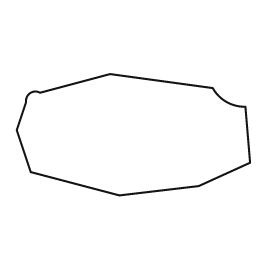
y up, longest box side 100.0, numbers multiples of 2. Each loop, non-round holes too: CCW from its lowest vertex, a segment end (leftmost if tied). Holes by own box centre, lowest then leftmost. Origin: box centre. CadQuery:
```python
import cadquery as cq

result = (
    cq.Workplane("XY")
    .moveTo(-6.0, -26.0)
    .lineTo(28.0, -22.0)
    .lineTo(50.0, -12.0)
    .lineTo(48.0, 12.0)
    .threePointArc((40.0, 14.0), (34.0, 20.0))
    .lineTo(-10.0, 26.0)
    .lineTo(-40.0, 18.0)
    .threePointArc((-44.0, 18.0), (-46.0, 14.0))
    .lineTo(-50.0, 2.0)
    .lineTo(-44.0, -16.0)
    .close()
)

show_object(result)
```